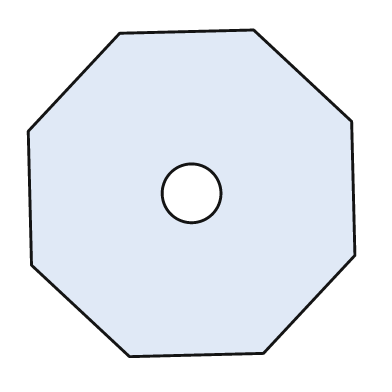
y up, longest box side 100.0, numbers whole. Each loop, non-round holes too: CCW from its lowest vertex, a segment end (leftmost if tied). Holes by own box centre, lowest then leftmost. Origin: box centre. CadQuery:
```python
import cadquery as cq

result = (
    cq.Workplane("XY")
    .moveTo(-19.0, -50.0)
    .lineTo(22.0, -49.0)
    .lineTo(50.0, -19.0)
    .lineTo(49.0, 22.0)
    .lineTo(19.0, 50.0)
    .lineTo(-22.0, 49.0)
    .lineTo(-50.0, 19.0)
    .lineTo(-49.0, -22.0)
    .close()
    .moveTo(0.0, 0.0)
    .circle(9.0)
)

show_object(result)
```